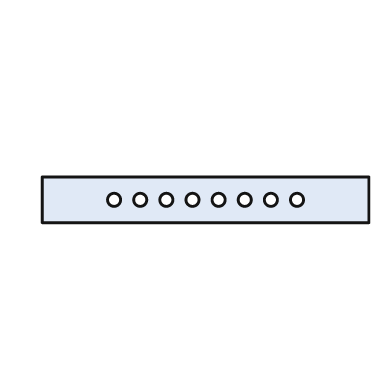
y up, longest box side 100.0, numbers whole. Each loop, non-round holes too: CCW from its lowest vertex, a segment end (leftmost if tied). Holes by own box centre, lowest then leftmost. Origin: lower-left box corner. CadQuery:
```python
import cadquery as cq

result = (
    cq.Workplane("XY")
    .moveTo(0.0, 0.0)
    .lineTo(100.0, 0.0)
    .lineTo(100.0, 14.0)
    .lineTo(0.0, 14.0)
    .close()
    .moveTo(22.0, 7.0)
    .circle(2.0)
    .moveTo(30.0, 7.0)
    .circle(2.0)
    .moveTo(38.0, 7.0)
    .circle(2.0)
    .moveTo(46.0, 7.0)
    .circle(2.0)
    .moveTo(54.0, 7.0)
    .circle(2.0)
    .moveTo(62.0, 7.0)
    .circle(2.0)
    .moveTo(70.0, 7.0)
    .circle(2.0)
    .moveTo(78.0, 7.0)
    .circle(2.0)
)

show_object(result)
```